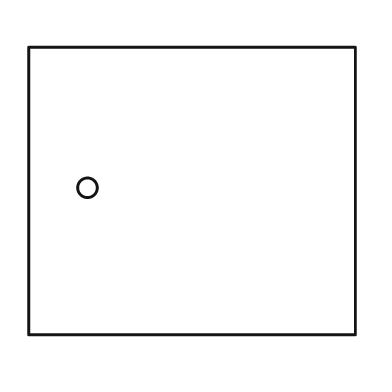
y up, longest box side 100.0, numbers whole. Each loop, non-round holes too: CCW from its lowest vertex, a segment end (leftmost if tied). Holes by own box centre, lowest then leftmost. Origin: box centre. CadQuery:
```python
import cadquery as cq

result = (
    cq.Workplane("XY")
    .moveTo(-50.0, -44.0)
    .lineTo(50.0, -44.0)
    .lineTo(50.0, 44.0)
    .lineTo(-50.0, 44.0)
    .close()
    .moveTo(-32.0, 1.0)
    .circle(3.0)
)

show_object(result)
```